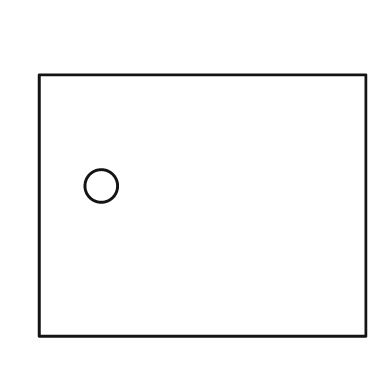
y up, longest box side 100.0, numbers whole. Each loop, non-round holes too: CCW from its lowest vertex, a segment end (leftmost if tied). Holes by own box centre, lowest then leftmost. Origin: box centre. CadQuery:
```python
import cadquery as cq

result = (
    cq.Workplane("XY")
    .moveTo(-50.0, -40.0)
    .lineTo(50.0, -40.0)
    .lineTo(50.0, 40.0)
    .lineTo(-50.0, 40.0)
    .close()
    .moveTo(-31.0, 6.0)
    .circle(5.0)
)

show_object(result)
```